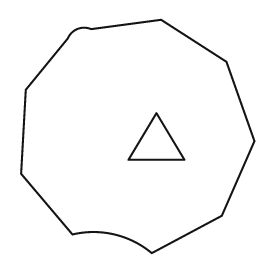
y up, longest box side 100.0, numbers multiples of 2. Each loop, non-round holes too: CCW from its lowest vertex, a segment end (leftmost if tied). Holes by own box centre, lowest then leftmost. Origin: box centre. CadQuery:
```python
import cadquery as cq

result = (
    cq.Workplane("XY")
    .moveTo(6.0, -50.0)
    .lineTo(36.0, -34.0)
    .lineTo(50.0, -2.0)
    .lineTo(38.0, 32.0)
    .lineTo(10.0, 50.0)
    .lineTo(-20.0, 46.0)
    .threePointArc((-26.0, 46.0), (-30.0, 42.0))
    .lineTo(-48.0, 20.0)
    .lineTo(-50.0, -16.0)
    .lineTo(-28.0, -42.0)
    .threePointArc((-10.0, -42.0), (6.0, -50.0))
    .close()
    .moveTo(-4.0, -10.0)
    .lineTo(20.0, -10.0)
    .lineTo(8.0, 10.0)
    .close()
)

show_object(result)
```